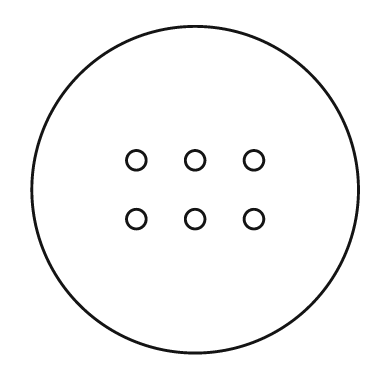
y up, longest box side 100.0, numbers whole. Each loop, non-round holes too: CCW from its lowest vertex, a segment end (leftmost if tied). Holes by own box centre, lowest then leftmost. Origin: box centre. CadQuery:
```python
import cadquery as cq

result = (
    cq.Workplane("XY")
    .moveTo(0.0, 0.0)
    .circle(50.0)
    .moveTo(-18.0, -9.0)
    .circle(3.0)
    .moveTo(0.0, -9.0)
    .circle(3.0)
    .moveTo(18.0, -9.0)
    .circle(3.0)
    .moveTo(-18.0, 9.0)
    .circle(3.0)
    .moveTo(0.0, 9.0)
    .circle(3.0)
    .moveTo(18.0, 9.0)
    .circle(3.0)
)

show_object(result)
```